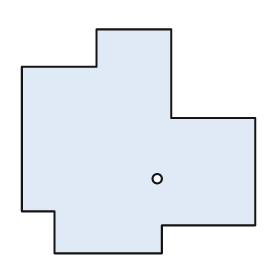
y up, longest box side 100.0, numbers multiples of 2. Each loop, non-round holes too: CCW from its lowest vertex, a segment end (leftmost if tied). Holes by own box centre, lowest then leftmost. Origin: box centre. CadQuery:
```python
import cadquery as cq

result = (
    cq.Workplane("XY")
    .moveTo(-36.0, -48.0)
    .lineTo(10.0, -48.0)
    .lineTo(10.0, -36.0)
    .lineTo(50.0, -36.0)
    .lineTo(50.0, 10.0)
    .lineTo(14.0, 10.0)
    .lineTo(14.0, 48.0)
    .lineTo(-18.0, 48.0)
    .lineTo(-18.0, 32.0)
    .lineTo(-50.0, 32.0)
    .lineTo(-50.0, -30.0)
    .lineTo(-36.0, -30.0)
    .close()
    .moveTo(8.0, -16.0)
    .circle(2.0)
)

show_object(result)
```